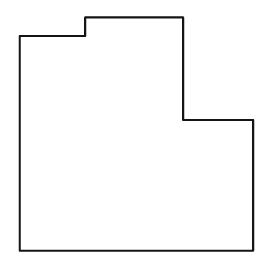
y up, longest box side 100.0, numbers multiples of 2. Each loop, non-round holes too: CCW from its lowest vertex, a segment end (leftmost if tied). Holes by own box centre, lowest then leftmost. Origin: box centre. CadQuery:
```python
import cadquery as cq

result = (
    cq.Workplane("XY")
    .moveTo(-50.0, -50.0)
    .lineTo(50.0, -50.0)
    .lineTo(50.0, 6.0)
    .lineTo(20.0, 6.0)
    .lineTo(20.0, 50.0)
    .lineTo(-22.0, 50.0)
    .lineTo(-22.0, 42.0)
    .lineTo(-50.0, 42.0)
    .close()
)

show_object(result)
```